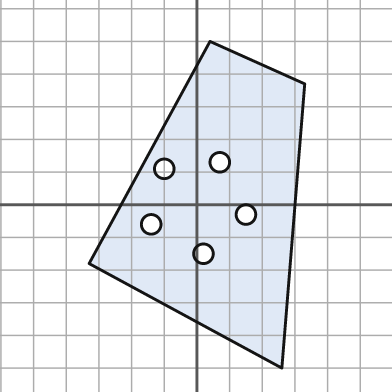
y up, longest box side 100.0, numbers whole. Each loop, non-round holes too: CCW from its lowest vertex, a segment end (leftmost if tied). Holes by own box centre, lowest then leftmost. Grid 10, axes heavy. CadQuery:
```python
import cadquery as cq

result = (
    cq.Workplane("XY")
    .moveTo(26.0, -50.0)
    .lineTo(33.0, 37.0)
    .lineTo(4.0, 50.0)
    .lineTo(-33.0, -18.0)
    .close()
    .moveTo(2.0, -15.0)
    .circle(3.0)
    .moveTo(-14.0, -6.0)
    .circle(3.0)
    .moveTo(15.0, -3.0)
    .circle(3.0)
    .moveTo(-10.0, 11.0)
    .circle(3.0)
    .moveTo(7.0, 13.0)
    .circle(3.0)
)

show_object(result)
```